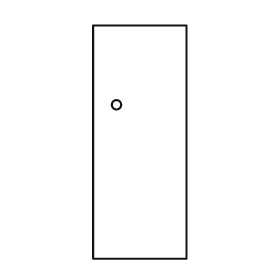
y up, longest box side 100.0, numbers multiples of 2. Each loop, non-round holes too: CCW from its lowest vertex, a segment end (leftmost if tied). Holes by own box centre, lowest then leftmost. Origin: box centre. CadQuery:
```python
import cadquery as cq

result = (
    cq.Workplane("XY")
    .moveTo(-20.0, -50.0)
    .lineTo(20.0, -50.0)
    .lineTo(20.0, 50.0)
    .lineTo(-20.0, 50.0)
    .close()
    .moveTo(-10.0, 16.0)
    .circle(2.0)
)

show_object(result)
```